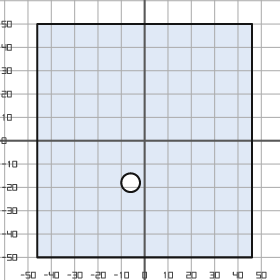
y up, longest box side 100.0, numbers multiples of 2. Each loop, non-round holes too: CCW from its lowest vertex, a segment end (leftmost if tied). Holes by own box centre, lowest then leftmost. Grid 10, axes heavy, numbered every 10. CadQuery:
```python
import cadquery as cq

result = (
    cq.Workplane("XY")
    .moveTo(-46.0, -50.0)
    .lineTo(46.0, -50.0)
    .lineTo(46.0, 50.0)
    .lineTo(-46.0, 50.0)
    .close()
    .moveTo(-6.0, -18.0)
    .circle(4.0)
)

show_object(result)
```